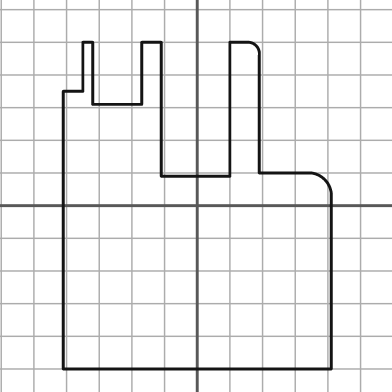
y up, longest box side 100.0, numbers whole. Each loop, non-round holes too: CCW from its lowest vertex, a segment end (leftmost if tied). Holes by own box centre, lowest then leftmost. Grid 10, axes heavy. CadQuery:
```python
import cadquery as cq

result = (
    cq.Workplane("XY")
    .moveTo(-41.0, -50.0)
    .lineTo(41.0, -50.0)
    .lineTo(41.0, 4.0)
    .threePointArc((39.0, 8.0), (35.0, 10.0))
    .lineTo(19.0, 10.0)
    .lineTo(19.0, 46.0)
    .threePointArc((18.0, 49.0), (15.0, 50.0))
    .lineTo(10.0, 50.0)
    .lineTo(10.0, 9.0)
    .lineTo(-11.0, 9.0)
    .lineTo(-11.0, 50.0)
    .lineTo(-17.0, 50.0)
    .lineTo(-17.0, 31.0)
    .lineTo(-32.0, 31.0)
    .lineTo(-32.0, 50.0)
    .lineTo(-35.0, 50.0)
    .lineTo(-35.0, 35.0)
    .lineTo(-41.0, 35.0)
    .close()
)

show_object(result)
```